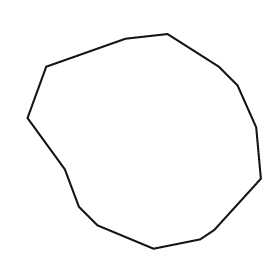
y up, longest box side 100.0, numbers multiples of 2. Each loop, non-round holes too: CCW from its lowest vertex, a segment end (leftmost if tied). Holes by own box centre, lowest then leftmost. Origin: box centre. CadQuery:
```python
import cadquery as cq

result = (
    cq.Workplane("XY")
    .moveTo(4.0, -46.0)
    .lineTo(24.0, -42.0)
    .lineTo(30.0, -38.0)
    .lineTo(50.0, -16.0)
    .lineTo(48.0, 6.0)
    .lineTo(40.0, 24.0)
    .lineTo(32.0, 32.0)
    .lineTo(10.0, 46.0)
    .lineTo(-8.0, 44.0)
    .lineTo(-42.0, 32.0)
    .lineTo(-50.0, 10.0)
    .lineTo(-34.0, -12.0)
    .lineTo(-28.0, -28.0)
    .lineTo(-20.0, -36.0)
    .close()
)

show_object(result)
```